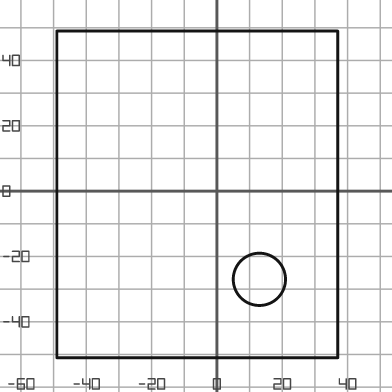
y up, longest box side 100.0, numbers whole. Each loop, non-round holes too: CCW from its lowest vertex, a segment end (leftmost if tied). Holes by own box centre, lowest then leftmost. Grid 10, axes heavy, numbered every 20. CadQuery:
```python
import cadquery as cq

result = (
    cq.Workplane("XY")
    .moveTo(-49.0, -51.0)
    .lineTo(37.0, -51.0)
    .lineTo(37.0, 49.0)
    .lineTo(-49.0, 49.0)
    .close()
    .moveTo(13.0, -27.0)
    .circle(8.0)
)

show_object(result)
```